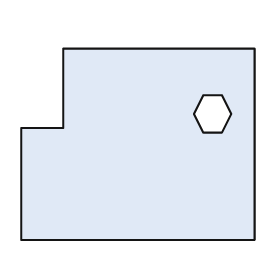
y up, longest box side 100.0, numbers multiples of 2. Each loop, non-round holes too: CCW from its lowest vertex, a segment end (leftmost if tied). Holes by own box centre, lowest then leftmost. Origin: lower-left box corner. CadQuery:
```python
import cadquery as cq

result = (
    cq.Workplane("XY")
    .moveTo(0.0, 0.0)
    .lineTo(100.0, 0.0)
    .lineTo(100.0, 82.0)
    .lineTo(18.0, 82.0)
    .lineTo(18.0, 48.0)
    .lineTo(0.0, 48.0)
    .close()
    .moveTo(78.0, 46.0)
    .lineTo(86.0, 46.0)
    .lineTo(90.0, 54.0)
    .lineTo(86.0, 62.0)
    .lineTo(78.0, 62.0)
    .lineTo(74.0, 54.0)
    .close()
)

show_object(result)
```